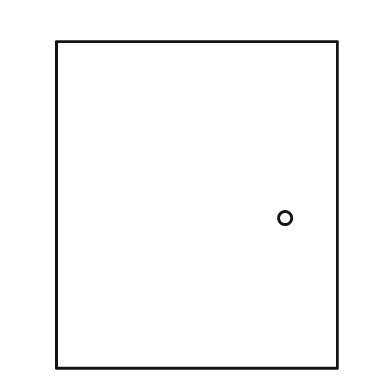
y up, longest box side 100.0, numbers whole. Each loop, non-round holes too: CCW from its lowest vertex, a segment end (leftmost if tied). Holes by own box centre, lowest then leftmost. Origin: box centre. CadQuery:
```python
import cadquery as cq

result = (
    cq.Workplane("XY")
    .moveTo(-43.0, -50.0)
    .lineTo(43.0, -50.0)
    .lineTo(43.0, 50.0)
    .lineTo(-43.0, 50.0)
    .close()
    .moveTo(27.0, -4.0)
    .circle(2.0)
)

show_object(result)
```